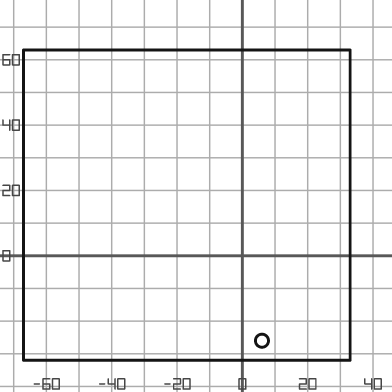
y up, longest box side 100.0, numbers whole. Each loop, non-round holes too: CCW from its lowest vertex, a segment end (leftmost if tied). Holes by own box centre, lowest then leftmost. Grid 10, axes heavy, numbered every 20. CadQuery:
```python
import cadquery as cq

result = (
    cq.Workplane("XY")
    .moveTo(-67.0, -32.0)
    .lineTo(33.0, -32.0)
    .lineTo(33.0, 63.0)
    .lineTo(-67.0, 63.0)
    .close()
    .moveTo(6.0, -26.0)
    .circle(2.0)
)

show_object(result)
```